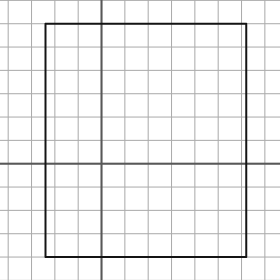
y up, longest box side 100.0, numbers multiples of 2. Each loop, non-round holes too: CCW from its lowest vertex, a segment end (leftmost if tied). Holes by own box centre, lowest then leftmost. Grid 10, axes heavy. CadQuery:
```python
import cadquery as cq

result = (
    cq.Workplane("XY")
    .moveTo(-24.0, -40.0)
    .lineTo(62.0, -40.0)
    .lineTo(62.0, 60.0)
    .lineTo(-24.0, 60.0)
    .close()
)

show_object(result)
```